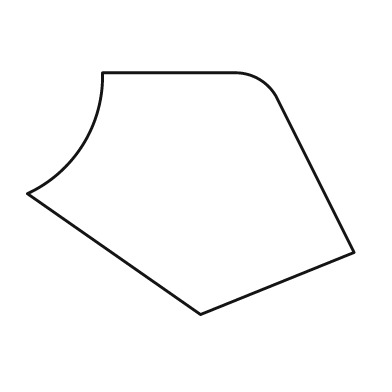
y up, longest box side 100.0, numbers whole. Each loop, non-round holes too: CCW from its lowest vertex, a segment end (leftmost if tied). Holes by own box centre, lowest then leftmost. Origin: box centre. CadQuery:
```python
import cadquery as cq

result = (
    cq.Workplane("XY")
    .moveTo(3.0, -37.0)
    .lineTo(50.0, -18.0)
    .lineTo(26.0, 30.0)
    .threePointArc((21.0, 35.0), (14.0, 37.0))
    .lineTo(-27.0, 37.0)
    .threePointArc((-33.0, 15.0), (-50.0, 0.0))
    .close()
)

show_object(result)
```